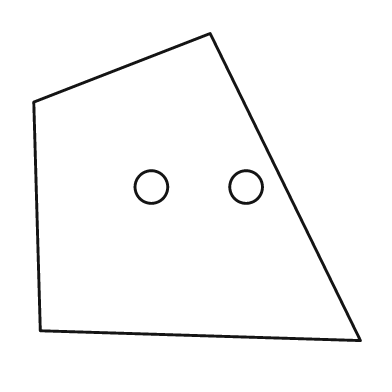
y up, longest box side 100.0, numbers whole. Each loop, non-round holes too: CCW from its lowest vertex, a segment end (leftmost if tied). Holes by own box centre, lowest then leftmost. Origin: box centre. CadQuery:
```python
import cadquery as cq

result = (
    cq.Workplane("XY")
    .moveTo(50.0, -47.0)
    .lineTo(4.0, 47.0)
    .lineTo(-50.0, 26.0)
    .lineTo(-48.0, -44.0)
    .close()
    .moveTo(-14.0, 0.0)
    .circle(5.0)
    .moveTo(15.0, 0.0)
    .circle(5.0)
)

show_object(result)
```